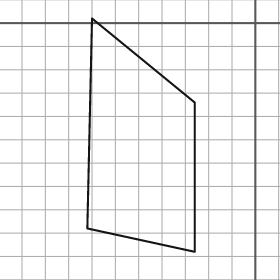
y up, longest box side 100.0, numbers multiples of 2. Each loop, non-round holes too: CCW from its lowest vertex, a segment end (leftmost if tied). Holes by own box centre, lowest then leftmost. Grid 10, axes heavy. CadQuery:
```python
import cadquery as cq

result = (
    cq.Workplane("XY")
    .moveTo(-26.0, -98.0)
    .lineTo(-26.0, -34.0)
    .lineTo(-70.0, 2.0)
    .lineTo(-72.0, -88.0)
    .close()
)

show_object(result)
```